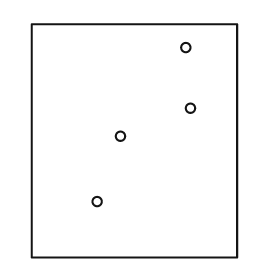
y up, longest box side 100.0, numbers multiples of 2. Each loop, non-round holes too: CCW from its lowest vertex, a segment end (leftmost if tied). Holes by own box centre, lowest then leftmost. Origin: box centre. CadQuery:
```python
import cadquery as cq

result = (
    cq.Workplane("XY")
    .moveTo(-44.0, -50.0)
    .lineTo(44.0, -50.0)
    .lineTo(44.0, 50.0)
    .lineTo(-44.0, 50.0)
    .close()
    .moveTo(-16.0, -26.0)
    .circle(2.0)
    .moveTo(-6.0, 2.0)
    .circle(2.0)
    .moveTo(24.0, 14.0)
    .circle(2.0)
    .moveTo(22.0, 40.0)
    .circle(2.0)
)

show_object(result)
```